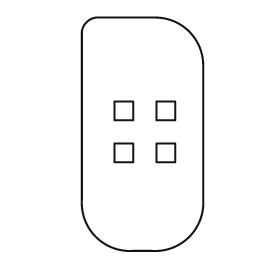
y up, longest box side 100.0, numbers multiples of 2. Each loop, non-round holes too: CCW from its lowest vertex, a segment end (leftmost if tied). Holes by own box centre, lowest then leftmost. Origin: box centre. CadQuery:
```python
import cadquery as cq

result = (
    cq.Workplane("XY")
    .moveTo(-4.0, -50.0)
    .lineTo(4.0, -50.0)
    .threePointArc((20.0, -44.0), (26.0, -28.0))
    .lineTo(26.0, 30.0)
    .threePointArc((20.0, 44.0), (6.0, 50.0))
    .lineTo(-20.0, 50.0)
    .threePointArc((-24.0, 48.0), (-26.0, 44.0))
    .lineTo(-26.0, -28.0)
    .threePointArc((-20.0, -44.0), (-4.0, -50.0))
    .close()
    .moveTo(-12.0, -12.0)
    .lineTo(-4.0, -12.0)
    .lineTo(-4.0, -4.0)
    .lineTo(-12.0, -4.0)
    .close()
    .moveTo(6.0, -12.0)
    .lineTo(14.0, -12.0)
    .lineTo(14.0, -4.0)
    .lineTo(6.0, -4.0)
    .close()
    .moveTo(-12.0, 6.0)
    .lineTo(-4.0, 6.0)
    .lineTo(-4.0, 14.0)
    .lineTo(-12.0, 14.0)
    .close()
    .moveTo(6.0, 6.0)
    .lineTo(14.0, 6.0)
    .lineTo(14.0, 14.0)
    .lineTo(6.0, 14.0)
    .close()
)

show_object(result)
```